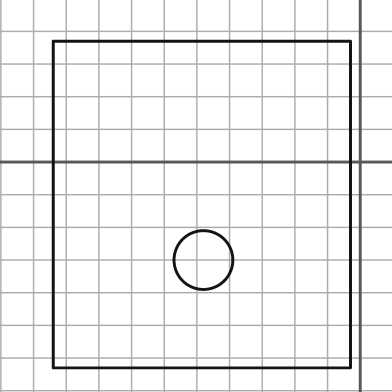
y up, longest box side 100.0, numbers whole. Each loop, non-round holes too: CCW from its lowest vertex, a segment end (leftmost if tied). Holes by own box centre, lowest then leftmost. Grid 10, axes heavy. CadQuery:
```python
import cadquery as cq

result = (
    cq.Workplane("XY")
    .moveTo(-94.0, -63.0)
    .lineTo(-3.0, -63.0)
    .lineTo(-3.0, 37.0)
    .lineTo(-94.0, 37.0)
    .close()
    .moveTo(-48.0, -30.0)
    .circle(9.0)
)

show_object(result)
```